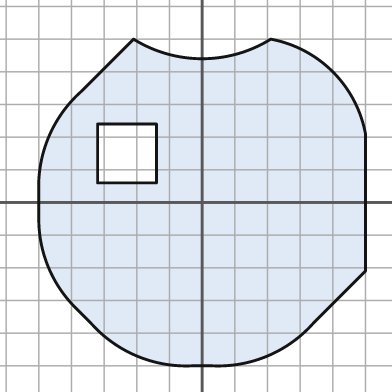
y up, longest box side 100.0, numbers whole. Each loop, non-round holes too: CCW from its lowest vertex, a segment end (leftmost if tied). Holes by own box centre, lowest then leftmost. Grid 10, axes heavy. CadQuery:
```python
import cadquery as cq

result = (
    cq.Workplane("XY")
    .moveTo(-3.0, -50.0)
    .lineTo(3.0, -50.0)
    .threePointArc((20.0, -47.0), (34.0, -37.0))
    .lineTo(50.0, -21.0)
    .lineTo(50.0, 21.0)
    .threePointArc((40.0, 40.0), (21.0, 50.0))
    .threePointArc((0.0, 44.0), (-21.0, 50.0))
    .lineTo(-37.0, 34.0)
    .threePointArc((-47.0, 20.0), (-50.0, 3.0))
    .lineTo(-50.0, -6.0)
    .threePointArc((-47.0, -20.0), (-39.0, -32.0))
    .lineTo(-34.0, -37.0)
    .threePointArc((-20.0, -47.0), (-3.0, -50.0))
    .close()
    .moveTo(-32.0, 6.0)
    .lineTo(-14.0, 6.0)
    .lineTo(-14.0, 24.0)
    .lineTo(-32.0, 24.0)
    .close()
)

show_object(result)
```